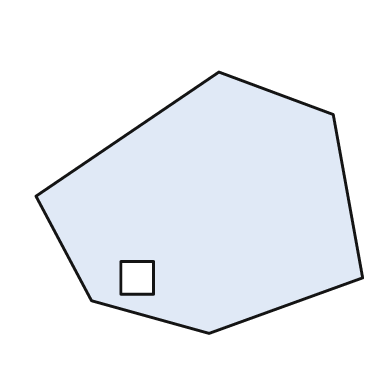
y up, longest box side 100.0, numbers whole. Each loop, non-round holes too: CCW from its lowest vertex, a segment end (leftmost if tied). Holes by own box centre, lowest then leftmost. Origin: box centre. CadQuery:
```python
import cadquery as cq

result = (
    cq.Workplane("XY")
    .moveTo(3.0, -40.0)
    .lineTo(50.0, -23.0)
    .lineTo(41.0, 27.0)
    .lineTo(6.0, 40.0)
    .lineTo(-50.0, 2.0)
    .lineTo(-33.0, -30.0)
    .close()
    .moveTo(-24.0, -28.0)
    .lineTo(-14.0, -28.0)
    .lineTo(-14.0, -18.0)
    .lineTo(-24.0, -18.0)
    .close()
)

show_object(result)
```